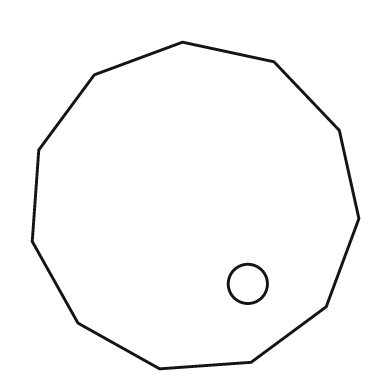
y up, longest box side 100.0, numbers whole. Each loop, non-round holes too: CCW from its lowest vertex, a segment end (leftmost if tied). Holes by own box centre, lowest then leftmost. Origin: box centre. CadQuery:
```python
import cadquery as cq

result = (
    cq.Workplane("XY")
    .moveTo(-11.0, -50.0)
    .lineTo(17.0, -48.0)
    .lineTo(40.0, -31.0)
    .lineTo(50.0, -4.0)
    .lineTo(44.0, 23.0)
    .lineTo(24.0, 44.0)
    .lineTo(-4.0, 50.0)
    .lineTo(-31.0, 40.0)
    .lineTo(-48.0, 17.0)
    .lineTo(-50.0, -11.0)
    .lineTo(-36.0, -36.0)
    .close()
    .moveTo(16.0, -24.0)
    .circle(6.0)
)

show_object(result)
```